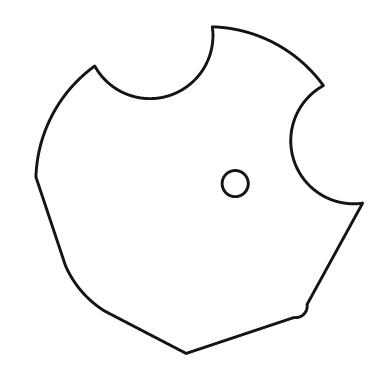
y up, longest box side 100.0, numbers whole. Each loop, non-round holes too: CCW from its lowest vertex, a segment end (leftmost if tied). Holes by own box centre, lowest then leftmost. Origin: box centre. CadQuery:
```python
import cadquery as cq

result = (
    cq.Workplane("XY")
    .moveTo(-4.0, -50.0)
    .lineTo(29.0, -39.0)
    .threePointArc((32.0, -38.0), (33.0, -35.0))
    .lineTo(50.0, -4.0)
    .threePointArc((29.0, 9.0), (38.0, 32.0))
    .threePointArc((23.0, 45.0), (4.0, 50.0))
    .threePointArc((-9.0, 29.0), (-32.0, 38.0))
    .threePointArc((-45.0, 23.0), (-50.0, 4.0))
    .lineTo(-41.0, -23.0)
    .threePointArc((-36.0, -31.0), (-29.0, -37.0))
    .close()
    .moveTo(11.0, 2.0)
    .circle(4.0)
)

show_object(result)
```